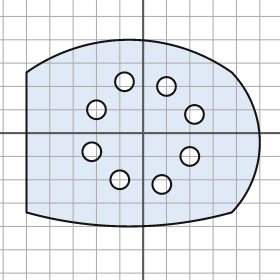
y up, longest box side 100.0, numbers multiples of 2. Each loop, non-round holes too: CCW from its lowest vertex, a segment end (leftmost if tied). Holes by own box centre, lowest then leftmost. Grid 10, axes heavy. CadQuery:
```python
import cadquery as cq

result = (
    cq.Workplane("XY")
    .moveTo(-50.0, -34.0)
    .threePointArc((-6.0, -40.0), (38.0, -34.0))
    .threePointArc((50.0, -4.0), (38.0, 26.0))
    .threePointArc((-6.0, 40.0), (-50.0, 26.0))
    .close()
    .moveTo(8.0, -22.0)
    .circle(4.0)
    .moveTo(-10.0, -20.0)
    .circle(4.0)
    .moveTo(20.0, -10.0)
    .circle(4.0)
    .moveTo(-22.0, -8.0)
    .circle(4.0)
    .moveTo(22.0, 8.0)
    .circle(4.0)
    .moveTo(-20.0, 10.0)
    .circle(4.0)
    .moveTo(10.0, 20.0)
    .circle(4.0)
    .moveTo(-8.0, 22.0)
    .circle(4.0)
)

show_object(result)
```